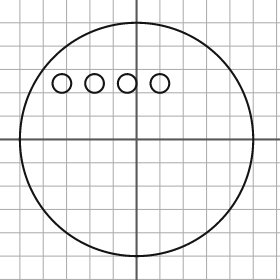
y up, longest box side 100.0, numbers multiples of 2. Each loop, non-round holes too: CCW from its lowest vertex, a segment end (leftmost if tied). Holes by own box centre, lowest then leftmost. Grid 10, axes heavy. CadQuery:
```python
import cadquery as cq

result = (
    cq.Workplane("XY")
    .moveTo(0.0, 0.0)
    .circle(50.0)
    .moveTo(-32.0, 24.0)
    .circle(4.0)
    .moveTo(-18.0, 24.0)
    .circle(4.0)
    .moveTo(-4.0, 24.0)
    .circle(4.0)
    .moveTo(10.0, 24.0)
    .circle(4.0)
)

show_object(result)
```